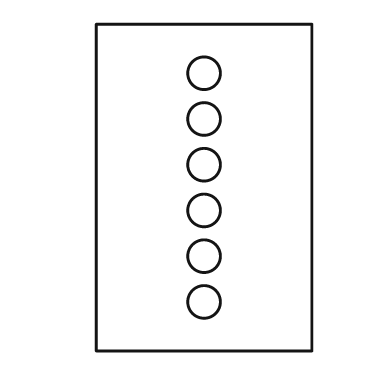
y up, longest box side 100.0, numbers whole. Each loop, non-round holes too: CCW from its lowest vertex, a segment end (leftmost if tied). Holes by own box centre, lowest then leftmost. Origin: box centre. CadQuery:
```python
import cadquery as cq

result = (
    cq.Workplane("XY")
    .moveTo(-33.0, -50.0)
    .lineTo(33.0, -50.0)
    .lineTo(33.0, 50.0)
    .lineTo(-33.0, 50.0)
    .close()
    .moveTo(0.0, -35.0)
    .circle(5.0)
    .moveTo(0.0, -21.0)
    .circle(5.0)
    .moveTo(0.0, -7.0)
    .circle(5.0)
    .moveTo(0.0, 7.0)
    .circle(5.0)
    .moveTo(0.0, 21.0)
    .circle(5.0)
    .moveTo(0.0, 35.0)
    .circle(5.0)
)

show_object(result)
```